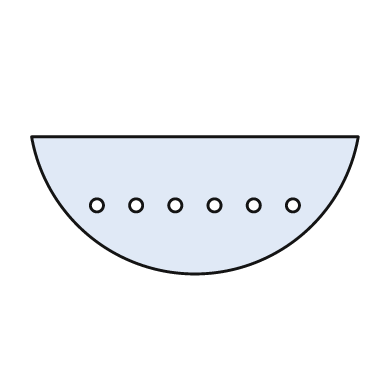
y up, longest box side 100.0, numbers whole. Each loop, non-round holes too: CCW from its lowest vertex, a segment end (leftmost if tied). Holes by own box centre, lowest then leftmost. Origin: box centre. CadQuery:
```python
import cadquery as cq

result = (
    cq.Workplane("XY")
    .moveTo(-50.0, 21.0)
    .threePointArc((0.0, -21.0), (50.0, 21.0))
    .close()
    .moveTo(-30.0, 0.0)
    .circle(2.0)
    .moveTo(-18.0, 0.0)
    .circle(2.0)
    .moveTo(-6.0, 0.0)
    .circle(2.0)
    .moveTo(6.0, 0.0)
    .circle(2.0)
    .moveTo(18.0, 0.0)
    .circle(2.0)
    .moveTo(30.0, 0.0)
    .circle(2.0)
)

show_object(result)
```